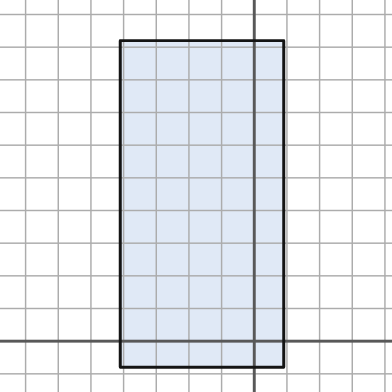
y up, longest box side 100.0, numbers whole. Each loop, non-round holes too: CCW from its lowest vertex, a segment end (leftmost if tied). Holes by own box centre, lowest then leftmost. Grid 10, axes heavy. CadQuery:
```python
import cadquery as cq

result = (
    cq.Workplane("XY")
    .moveTo(-41.0, -8.0)
    .lineTo(9.0, -8.0)
    .lineTo(9.0, 92.0)
    .lineTo(-41.0, 92.0)
    .close()
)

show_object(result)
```